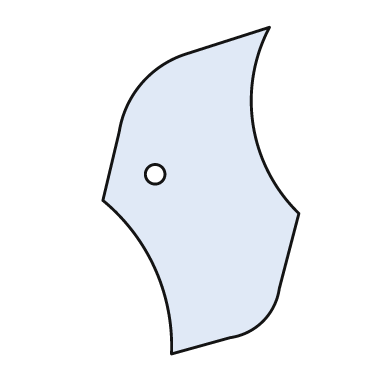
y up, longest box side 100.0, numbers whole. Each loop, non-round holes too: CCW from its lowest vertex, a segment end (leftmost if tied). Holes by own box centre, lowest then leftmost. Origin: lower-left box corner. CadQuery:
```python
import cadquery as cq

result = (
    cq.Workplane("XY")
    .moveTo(21.0, 0.0)
    .lineTo(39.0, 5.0)
    .threePointArc((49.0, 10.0), (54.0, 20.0))
    .lineTo(60.0, 43.0)
    .threePointArc((46.0, 70.0), (51.0, 100.0))
    .lineTo(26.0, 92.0)
    .threePointArc((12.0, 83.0), (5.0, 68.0))
    .lineTo(0.0, 47.0)
    .threePointArc((16.0, 26.0), (21.0, 0.0))
    .close()
    .moveTo(16.0, 55.0)
    .circle(3.0)
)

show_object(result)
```